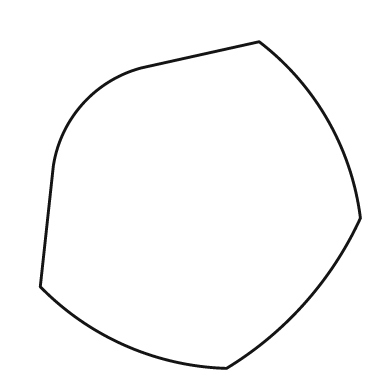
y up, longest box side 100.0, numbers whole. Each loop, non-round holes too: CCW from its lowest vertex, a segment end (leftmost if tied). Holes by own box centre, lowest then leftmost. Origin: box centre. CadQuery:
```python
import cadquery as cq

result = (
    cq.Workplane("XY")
    .moveTo(8.0, -50.0)
    .threePointArc((32.0, -30.0), (49.0, -4.0))
    .threePointArc((39.0, 26.0), (18.0, 50.0))
    .lineTo(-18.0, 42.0)
    .threePointArc((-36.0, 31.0), (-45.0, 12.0))
    .lineTo(-49.0, -25.0)
    .threePointArc((-23.0, -43.0), (8.0, -50.0))
    .close()
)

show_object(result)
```